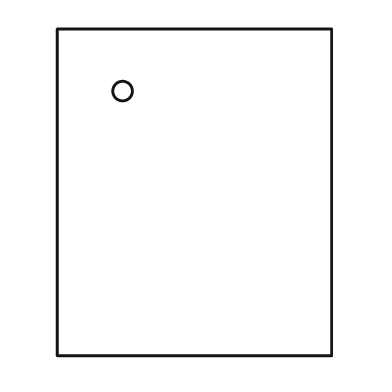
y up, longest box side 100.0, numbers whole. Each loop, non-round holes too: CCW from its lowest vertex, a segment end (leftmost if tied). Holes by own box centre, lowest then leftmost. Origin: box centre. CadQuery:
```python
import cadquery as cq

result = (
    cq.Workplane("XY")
    .moveTo(-42.0, -50.0)
    .lineTo(42.0, -50.0)
    .lineTo(42.0, 50.0)
    .lineTo(-42.0, 50.0)
    .close()
    .moveTo(-22.0, 31.0)
    .circle(3.0)
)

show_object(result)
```